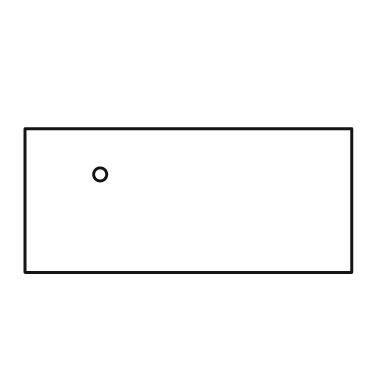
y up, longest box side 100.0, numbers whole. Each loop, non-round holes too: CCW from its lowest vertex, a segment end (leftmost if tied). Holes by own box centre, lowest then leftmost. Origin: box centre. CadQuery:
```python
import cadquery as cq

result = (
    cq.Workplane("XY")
    .moveTo(-50.0, -22.0)
    .lineTo(50.0, -22.0)
    .lineTo(50.0, 22.0)
    .lineTo(-50.0, 22.0)
    .close()
    .moveTo(-27.0, 8.0)
    .circle(2.0)
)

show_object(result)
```